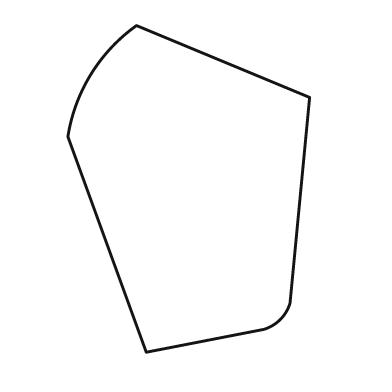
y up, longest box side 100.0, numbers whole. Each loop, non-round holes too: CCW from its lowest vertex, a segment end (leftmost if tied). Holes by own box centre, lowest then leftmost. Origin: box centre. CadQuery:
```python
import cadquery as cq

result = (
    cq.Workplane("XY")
    .moveTo(-13.0, -50.0)
    .lineTo(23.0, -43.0)
    .threePointArc((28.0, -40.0), (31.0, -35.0))
    .lineTo(37.0, 28.0)
    .lineTo(-16.0, 50.0)
    .threePointArc((-30.0, 35.0), (-37.0, 16.0))
    .close()
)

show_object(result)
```